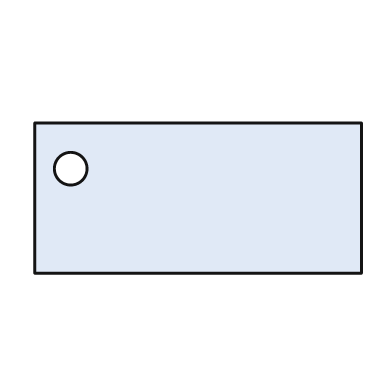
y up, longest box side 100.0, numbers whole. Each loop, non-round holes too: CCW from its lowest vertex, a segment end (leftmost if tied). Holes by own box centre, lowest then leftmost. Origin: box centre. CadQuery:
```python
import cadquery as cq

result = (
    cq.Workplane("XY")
    .moveTo(-50.0, -23.0)
    .lineTo(50.0, -23.0)
    .lineTo(50.0, 23.0)
    .lineTo(-50.0, 23.0)
    .close()
    .moveTo(-39.0, 9.0)
    .circle(5.0)
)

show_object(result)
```